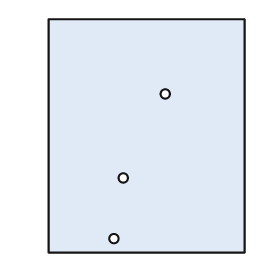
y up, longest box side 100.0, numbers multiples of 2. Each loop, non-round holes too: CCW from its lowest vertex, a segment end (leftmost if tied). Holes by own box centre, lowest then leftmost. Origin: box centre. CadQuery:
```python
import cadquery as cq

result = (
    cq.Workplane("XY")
    .moveTo(-42.0, -50.0)
    .lineTo(42.0, -50.0)
    .lineTo(42.0, 50.0)
    .lineTo(-42.0, 50.0)
    .close()
    .moveTo(-14.0, -44.0)
    .circle(2.0)
    .moveTo(-10.0, -18.0)
    .circle(2.0)
    .moveTo(8.0, 18.0)
    .circle(2.0)
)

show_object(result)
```